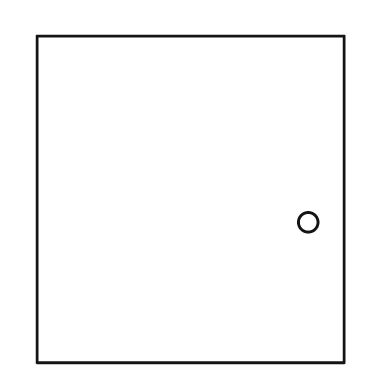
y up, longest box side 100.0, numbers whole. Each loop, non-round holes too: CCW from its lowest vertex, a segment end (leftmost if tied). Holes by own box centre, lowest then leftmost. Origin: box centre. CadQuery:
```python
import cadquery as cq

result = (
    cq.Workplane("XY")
    .moveTo(-47.0, -50.0)
    .lineTo(47.0, -50.0)
    .lineTo(47.0, 50.0)
    .lineTo(-47.0, 50.0)
    .close()
    .moveTo(36.0, -7.0)
    .circle(3.0)
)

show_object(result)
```